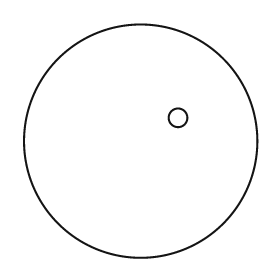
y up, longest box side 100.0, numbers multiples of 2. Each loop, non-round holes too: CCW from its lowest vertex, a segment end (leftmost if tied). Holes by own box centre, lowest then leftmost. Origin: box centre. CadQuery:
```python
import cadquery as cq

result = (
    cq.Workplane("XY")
    .moveTo(0.0, 0.0)
    .circle(50.0)
    .moveTo(16.0, 10.0)
    .circle(4.0)
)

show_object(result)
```